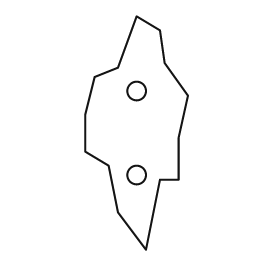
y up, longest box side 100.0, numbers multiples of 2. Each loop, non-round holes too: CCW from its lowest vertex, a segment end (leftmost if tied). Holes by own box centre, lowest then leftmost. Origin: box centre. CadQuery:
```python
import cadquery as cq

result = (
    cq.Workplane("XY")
    .moveTo(4.0, -50.0)
    .lineTo(10.0, -20.0)
    .lineTo(18.0, -20.0)
    .lineTo(18.0, -2.0)
    .lineTo(22.0, 16.0)
    .lineTo(12.0, 30.0)
    .lineTo(10.0, 44.0)
    .lineTo(0.0, 50.0)
    .lineTo(-8.0, 28.0)
    .lineTo(-18.0, 24.0)
    .lineTo(-22.0, 8.0)
    .lineTo(-22.0, -8.0)
    .lineTo(-12.0, -14.0)
    .lineTo(-8.0, -34.0)
    .close()
    .moveTo(0.0, -18.0)
    .circle(4.0)
    .moveTo(0.0, 18.0)
    .circle(4.0)
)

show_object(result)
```